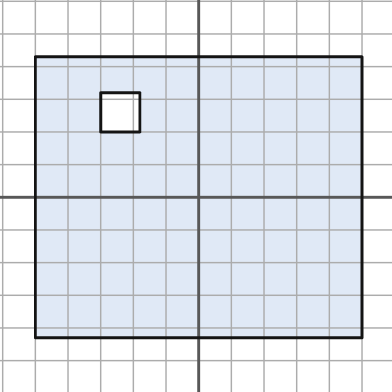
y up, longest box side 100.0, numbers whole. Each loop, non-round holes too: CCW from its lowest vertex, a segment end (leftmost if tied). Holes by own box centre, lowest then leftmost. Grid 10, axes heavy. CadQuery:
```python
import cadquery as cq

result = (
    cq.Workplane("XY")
    .moveTo(-50.0, -43.0)
    .lineTo(50.0, -43.0)
    .lineTo(50.0, 43.0)
    .lineTo(-50.0, 43.0)
    .close()
    .moveTo(-30.0, 20.0)
    .lineTo(-18.0, 20.0)
    .lineTo(-18.0, 32.0)
    .lineTo(-30.0, 32.0)
    .close()
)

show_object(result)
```